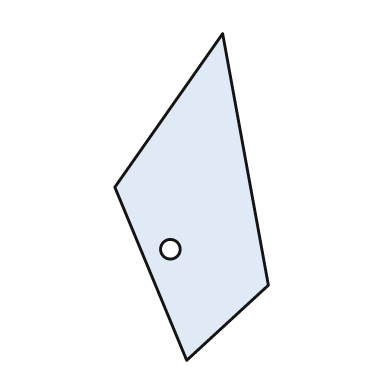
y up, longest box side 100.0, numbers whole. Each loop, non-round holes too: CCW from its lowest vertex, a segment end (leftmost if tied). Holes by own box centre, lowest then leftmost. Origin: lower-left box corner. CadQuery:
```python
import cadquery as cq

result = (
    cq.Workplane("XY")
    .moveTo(22.0, 0.0)
    .lineTo(47.0, 23.0)
    .lineTo(33.0, 100.0)
    .lineTo(0.0, 53.0)
    .close()
    .moveTo(17.0, 34.0)
    .circle(3.0)
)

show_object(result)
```